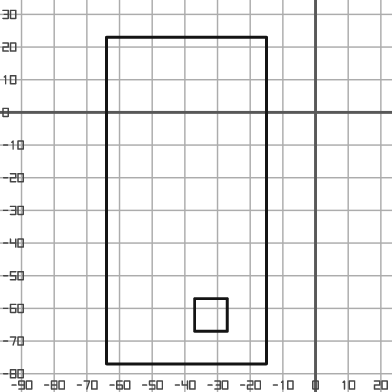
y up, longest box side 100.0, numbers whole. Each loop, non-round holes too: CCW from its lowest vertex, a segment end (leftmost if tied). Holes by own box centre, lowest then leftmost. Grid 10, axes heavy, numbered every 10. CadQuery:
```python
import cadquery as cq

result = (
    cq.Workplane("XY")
    .moveTo(-64.0, -77.0)
    .lineTo(-15.0, -77.0)
    .lineTo(-15.0, 23.0)
    .lineTo(-64.0, 23.0)
    .close()
    .moveTo(-37.0, -67.0)
    .lineTo(-27.0, -67.0)
    .lineTo(-27.0, -57.0)
    .lineTo(-37.0, -57.0)
    .close()
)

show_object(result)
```